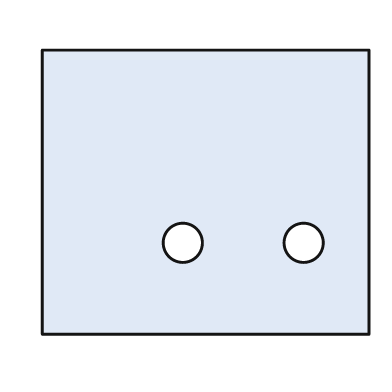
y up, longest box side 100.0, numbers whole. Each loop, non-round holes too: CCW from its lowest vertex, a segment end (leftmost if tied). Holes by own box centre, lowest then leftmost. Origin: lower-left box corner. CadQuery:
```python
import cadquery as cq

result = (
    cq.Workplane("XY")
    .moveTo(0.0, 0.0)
    .lineTo(100.0, 0.0)
    .lineTo(100.0, 87.0)
    .lineTo(0.0, 87.0)
    .close()
    .moveTo(43.0, 28.0)
    .circle(6.0)
    .moveTo(80.0, 28.0)
    .circle(6.0)
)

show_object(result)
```